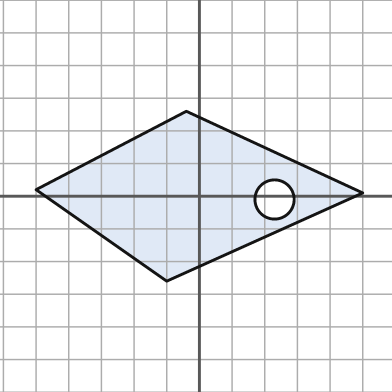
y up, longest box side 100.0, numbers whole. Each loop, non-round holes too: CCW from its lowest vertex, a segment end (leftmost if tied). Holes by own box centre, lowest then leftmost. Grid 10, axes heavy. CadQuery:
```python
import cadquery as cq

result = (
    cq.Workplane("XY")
    .moveTo(-10.0, -26.0)
    .lineTo(50.0, 1.0)
    .lineTo(-4.0, 26.0)
    .lineTo(-50.0, 2.0)
    .close()
    .moveTo(23.0, -1.0)
    .circle(6.0)
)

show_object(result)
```